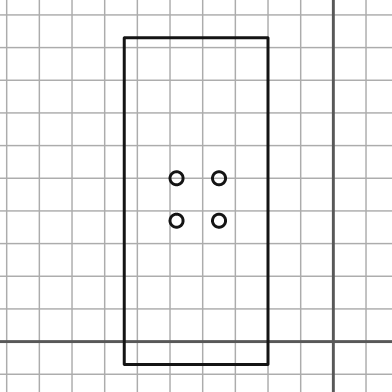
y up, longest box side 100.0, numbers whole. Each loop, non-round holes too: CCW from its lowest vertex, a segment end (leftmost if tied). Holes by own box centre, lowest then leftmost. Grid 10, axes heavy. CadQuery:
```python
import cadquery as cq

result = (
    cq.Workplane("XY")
    .moveTo(-64.0, -7.0)
    .lineTo(-20.0, -7.0)
    .lineTo(-20.0, 93.0)
    .lineTo(-64.0, 93.0)
    .close()
    .moveTo(-48.0, 37.0)
    .circle(2.0)
    .moveTo(-35.0, 37.0)
    .circle(2.0)
    .moveTo(-48.0, 50.0)
    .circle(2.0)
    .moveTo(-35.0, 50.0)
    .circle(2.0)
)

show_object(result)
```